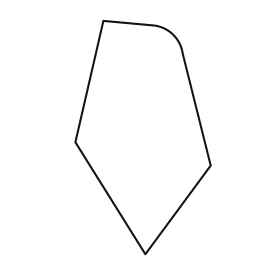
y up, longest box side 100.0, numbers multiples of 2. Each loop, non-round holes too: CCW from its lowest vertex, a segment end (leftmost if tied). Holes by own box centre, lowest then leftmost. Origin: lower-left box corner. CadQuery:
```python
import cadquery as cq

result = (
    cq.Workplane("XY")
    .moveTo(30.0, 0.0)
    .lineTo(58.0, 38.0)
    .lineTo(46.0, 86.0)
    .threePointArc((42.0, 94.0), (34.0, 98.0))
    .lineTo(12.0, 100.0)
    .lineTo(0.0, 48.0)
    .close()
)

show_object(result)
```